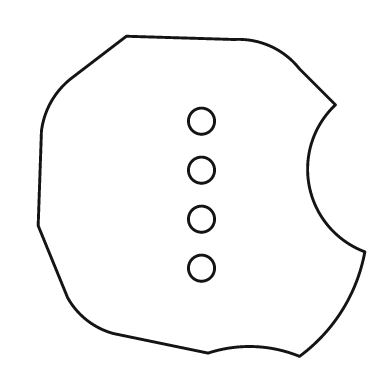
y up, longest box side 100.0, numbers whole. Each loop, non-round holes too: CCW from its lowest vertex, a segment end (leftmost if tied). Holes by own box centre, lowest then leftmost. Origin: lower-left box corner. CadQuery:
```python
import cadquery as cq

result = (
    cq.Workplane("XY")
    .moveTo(80.0, 0.0)
    .threePointArc((93.0, 14.0), (100.0, 32.0))
    .threePointArc((83.0, 52.0), (91.0, 77.0))
    .lineTo(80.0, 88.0)
    .threePointArc((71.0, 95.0), (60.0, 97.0))
    .lineTo(27.0, 98.0)
    .lineTo(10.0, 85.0)
    .threePointArc((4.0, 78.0), (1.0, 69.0))
    .lineTo(0.0, 40.0)
    .lineTo(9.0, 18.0)
    .threePointArc((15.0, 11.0), (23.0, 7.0))
    .lineTo(52.0, 1.0)
    .threePointArc((66.0, 3.0), (80.0, 0.0))
    .close()
    .moveTo(50.0, 27.0)
    .circle(4.0)
    .moveTo(50.0, 42.0)
    .circle(4.0)
    .moveTo(50.0, 57.0)
    .circle(4.0)
    .moveTo(50.0, 72.0)
    .circle(4.0)
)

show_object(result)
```